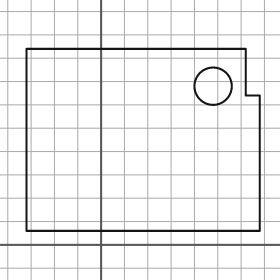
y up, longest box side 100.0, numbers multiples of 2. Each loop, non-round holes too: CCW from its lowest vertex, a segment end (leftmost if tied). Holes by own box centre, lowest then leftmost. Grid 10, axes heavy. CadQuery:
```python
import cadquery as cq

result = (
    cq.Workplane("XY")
    .moveTo(-32.0, 6.0)
    .lineTo(68.0, 6.0)
    .lineTo(68.0, 64.0)
    .lineTo(62.0, 64.0)
    .lineTo(62.0, 84.0)
    .lineTo(-32.0, 84.0)
    .close()
    .moveTo(48.0, 68.0)
    .circle(8.0)
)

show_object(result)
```